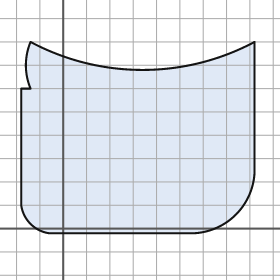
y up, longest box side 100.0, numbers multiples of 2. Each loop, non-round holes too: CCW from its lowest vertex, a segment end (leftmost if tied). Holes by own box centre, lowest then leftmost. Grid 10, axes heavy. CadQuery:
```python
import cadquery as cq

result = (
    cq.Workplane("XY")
    .moveTo(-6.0, -2.0)
    .lineTo(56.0, -2.0)
    .threePointArc((74.0, 6.0), (82.0, 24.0))
    .lineTo(82.0, 80.0)
    .threePointArc((34.0, 68.0), (-14.0, 80.0))
    .threePointArc((-16.0, 70.0), (-14.0, 60.0))
    .lineTo(-18.0, 60.0)
    .lineTo(-18.0, 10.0)
    .threePointArc((-14.0, 2.0), (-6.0, -2.0))
    .close()
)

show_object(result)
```